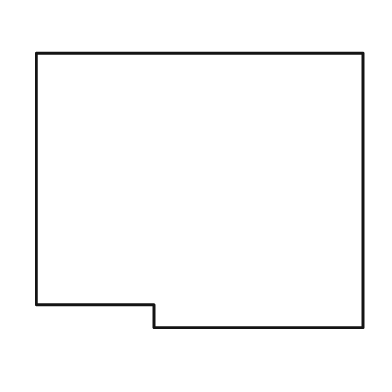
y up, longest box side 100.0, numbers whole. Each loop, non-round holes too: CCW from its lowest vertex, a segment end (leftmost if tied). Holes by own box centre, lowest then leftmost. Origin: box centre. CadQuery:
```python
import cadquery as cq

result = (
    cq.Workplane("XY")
    .moveTo(-14.0, -42.0)
    .lineTo(50.0, -42.0)
    .lineTo(50.0, 42.0)
    .lineTo(-50.0, 42.0)
    .lineTo(-50.0, -35.0)
    .lineTo(-14.0, -35.0)
    .close()
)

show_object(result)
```